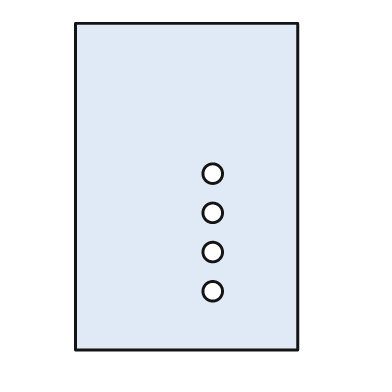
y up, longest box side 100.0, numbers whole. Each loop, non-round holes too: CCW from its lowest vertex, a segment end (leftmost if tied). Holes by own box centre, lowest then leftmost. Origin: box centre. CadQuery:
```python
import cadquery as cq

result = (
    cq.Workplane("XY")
    .moveTo(-34.0, -50.0)
    .lineTo(34.0, -50.0)
    .lineTo(34.0, 50.0)
    .lineTo(-34.0, 50.0)
    .close()
    .moveTo(8.0, -32.0)
    .circle(3.0)
    .moveTo(8.0, -20.0)
    .circle(3.0)
    .moveTo(8.0, -8.0)
    .circle(3.0)
    .moveTo(8.0, 4.0)
    .circle(3.0)
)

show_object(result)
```